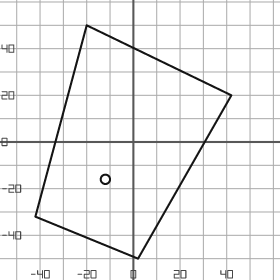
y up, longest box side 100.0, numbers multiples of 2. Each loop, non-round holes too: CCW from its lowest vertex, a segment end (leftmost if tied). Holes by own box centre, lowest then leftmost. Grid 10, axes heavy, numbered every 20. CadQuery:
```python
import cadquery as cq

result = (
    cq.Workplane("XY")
    .moveTo(2.0, -50.0)
    .lineTo(42.0, 20.0)
    .lineTo(-20.0, 50.0)
    .lineTo(-42.0, -32.0)
    .close()
    .moveTo(-12.0, -16.0)
    .circle(2.0)
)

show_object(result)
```